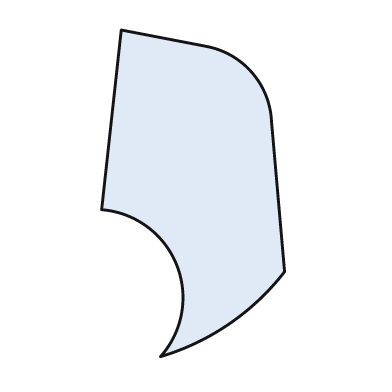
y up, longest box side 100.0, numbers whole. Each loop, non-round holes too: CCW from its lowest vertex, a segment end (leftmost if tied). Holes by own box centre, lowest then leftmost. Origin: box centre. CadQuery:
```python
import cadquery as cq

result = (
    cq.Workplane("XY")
    .moveTo(-10.0, -50.0)
    .threePointArc((11.0, -40.0), (28.0, -24.0))
    .lineTo(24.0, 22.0)
    .threePointArc((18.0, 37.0), (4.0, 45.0))
    .lineTo(-22.0, 50.0)
    .lineTo(-28.0, -5.0)
    .threePointArc((-5.0, -22.0), (-10.0, -50.0))
    .close()
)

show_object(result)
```